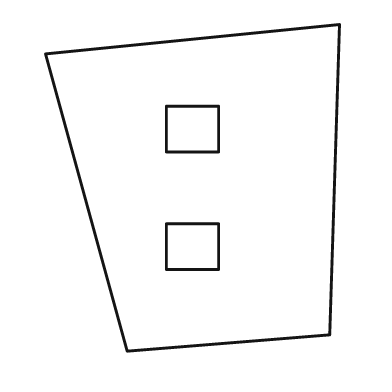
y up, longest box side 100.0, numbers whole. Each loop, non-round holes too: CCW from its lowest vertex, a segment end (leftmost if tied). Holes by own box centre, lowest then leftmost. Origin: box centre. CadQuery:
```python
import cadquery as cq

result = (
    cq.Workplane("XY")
    .moveTo(-20.0, -50.0)
    .lineTo(42.0, -45.0)
    .lineTo(45.0, 50.0)
    .lineTo(-45.0, 41.0)
    .close()
    .moveTo(-8.0, -25.0)
    .lineTo(8.0, -25.0)
    .lineTo(8.0, -11.0)
    .lineTo(-8.0, -11.0)
    .close()
    .moveTo(-8.0, 11.0)
    .lineTo(8.0, 11.0)
    .lineTo(8.0, 25.0)
    .lineTo(-8.0, 25.0)
    .close()
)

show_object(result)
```